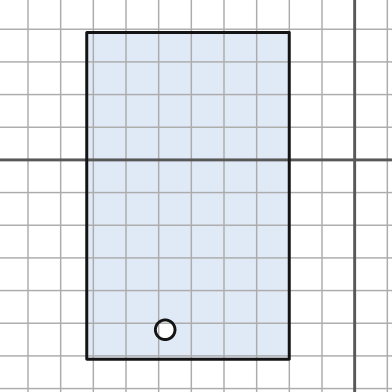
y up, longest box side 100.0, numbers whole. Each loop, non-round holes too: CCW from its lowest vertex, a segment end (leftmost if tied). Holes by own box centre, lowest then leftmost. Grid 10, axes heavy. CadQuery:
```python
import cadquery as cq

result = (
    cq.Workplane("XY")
    .moveTo(-82.0, -61.0)
    .lineTo(-20.0, -61.0)
    .lineTo(-20.0, 39.0)
    .lineTo(-82.0, 39.0)
    .close()
    .moveTo(-58.0, -52.0)
    .circle(3.0)
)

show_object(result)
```